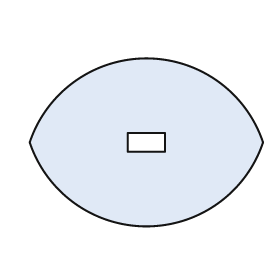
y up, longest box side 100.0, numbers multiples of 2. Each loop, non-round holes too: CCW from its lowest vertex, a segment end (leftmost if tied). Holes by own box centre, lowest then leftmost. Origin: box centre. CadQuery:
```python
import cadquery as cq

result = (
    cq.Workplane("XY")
    .moveTo(-50.0, 0.0)
    .threePointArc((0.0, -36.0), (50.0, 0.0))
    .threePointArc((0.0, 36.0), (-50.0, 0.0))
    .close()
    .moveTo(-8.0, -4.0)
    .lineTo(8.0, -4.0)
    .lineTo(8.0, 4.0)
    .lineTo(-8.0, 4.0)
    .close()
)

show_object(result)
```